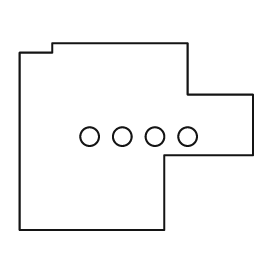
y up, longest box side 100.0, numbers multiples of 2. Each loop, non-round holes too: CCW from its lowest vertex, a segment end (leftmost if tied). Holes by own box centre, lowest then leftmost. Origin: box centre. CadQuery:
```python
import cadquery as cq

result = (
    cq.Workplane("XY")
    .moveTo(-50.0, -40.0)
    .lineTo(12.0, -40.0)
    .lineTo(12.0, -8.0)
    .lineTo(50.0, -8.0)
    .lineTo(50.0, 18.0)
    .lineTo(22.0, 18.0)
    .lineTo(22.0, 40.0)
    .lineTo(-36.0, 40.0)
    .lineTo(-36.0, 36.0)
    .lineTo(-50.0, 36.0)
    .close()
    .moveTo(-20.0, 0.0)
    .circle(4.0)
    .moveTo(-6.0, 0.0)
    .circle(4.0)
    .moveTo(8.0, 0.0)
    .circle(4.0)
    .moveTo(22.0, 0.0)
    .circle(4.0)
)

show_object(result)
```